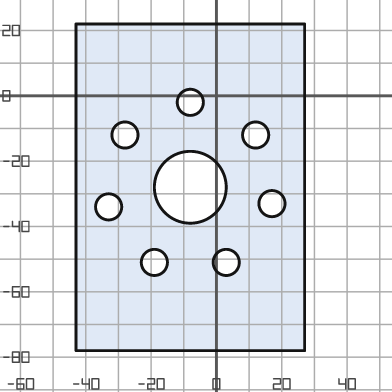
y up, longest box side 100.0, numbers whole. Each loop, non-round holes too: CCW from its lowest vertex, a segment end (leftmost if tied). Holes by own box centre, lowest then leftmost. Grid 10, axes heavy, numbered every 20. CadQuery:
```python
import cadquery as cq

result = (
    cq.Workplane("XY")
    .moveTo(-43.0, -78.0)
    .lineTo(27.0, -78.0)
    .lineTo(27.0, 22.0)
    .lineTo(-43.0, 22.0)
    .close()
    .moveTo(-19.0, -51.0)
    .circle(4.0)
    .moveTo(3.0, -51.0)
    .circle(4.0)
    .moveTo(-33.0, -34.0)
    .circle(4.0)
    .moveTo(17.0, -33.0)
    .circle(4.0)
    .moveTo(-8.0, -28.0)
    .circle(11.0)
    .moveTo(-28.0, -12.0)
    .circle(4.0)
    .moveTo(12.0, -12.0)
    .circle(4.0)
    .moveTo(-8.0, -2.0)
    .circle(4.0)
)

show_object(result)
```